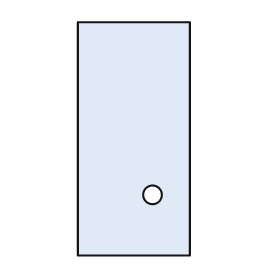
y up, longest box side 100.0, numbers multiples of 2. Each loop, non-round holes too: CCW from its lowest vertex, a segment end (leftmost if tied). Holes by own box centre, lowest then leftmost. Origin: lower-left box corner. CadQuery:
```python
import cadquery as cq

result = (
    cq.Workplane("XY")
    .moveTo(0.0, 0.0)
    .lineTo(48.0, 0.0)
    .lineTo(48.0, 100.0)
    .lineTo(0.0, 100.0)
    .close()
    .moveTo(32.0, 26.0)
    .circle(4.0)
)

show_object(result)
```